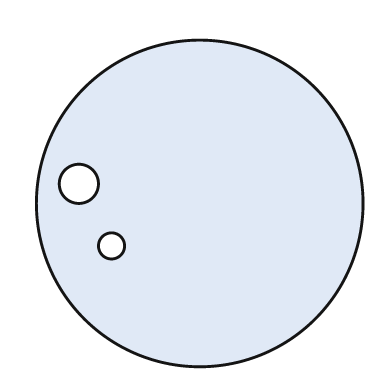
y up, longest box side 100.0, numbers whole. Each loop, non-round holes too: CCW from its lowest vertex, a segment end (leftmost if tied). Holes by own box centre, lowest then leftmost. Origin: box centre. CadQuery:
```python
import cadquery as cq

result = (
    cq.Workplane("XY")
    .moveTo(0.0, 0.0)
    .circle(50.0)
    .moveTo(-27.0, -13.0)
    .circle(4.0)
    .moveTo(-37.0, 6.0)
    .circle(6.0)
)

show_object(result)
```